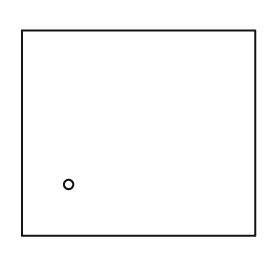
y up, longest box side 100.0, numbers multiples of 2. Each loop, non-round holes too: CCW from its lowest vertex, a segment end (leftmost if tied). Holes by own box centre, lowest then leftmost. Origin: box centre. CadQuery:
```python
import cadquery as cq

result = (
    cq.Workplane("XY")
    .moveTo(-50.0, -44.0)
    .lineTo(50.0, -44.0)
    .lineTo(50.0, 44.0)
    .lineTo(-50.0, 44.0)
    .close()
    .moveTo(-30.0, -22.0)
    .circle(2.0)
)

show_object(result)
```